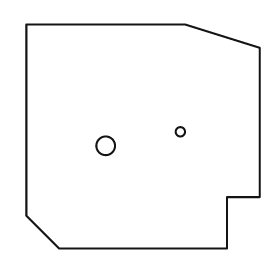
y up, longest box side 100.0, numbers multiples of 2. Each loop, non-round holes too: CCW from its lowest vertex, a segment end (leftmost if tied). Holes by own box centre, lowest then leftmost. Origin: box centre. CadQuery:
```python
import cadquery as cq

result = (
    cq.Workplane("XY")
    .moveTo(-36.0, -48.0)
    .lineTo(36.0, -48.0)
    .lineTo(36.0, -26.0)
    .lineTo(50.0, -26.0)
    .lineTo(50.0, 38.0)
    .lineTo(18.0, 48.0)
    .lineTo(-50.0, 48.0)
    .lineTo(-50.0, -34.0)
    .close()
    .moveTo(-16.0, -4.0)
    .circle(4.0)
    .moveTo(16.0, 2.0)
    .circle(2.0)
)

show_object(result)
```